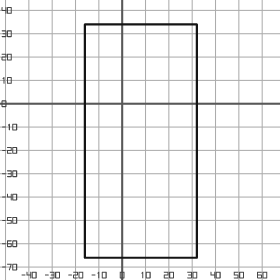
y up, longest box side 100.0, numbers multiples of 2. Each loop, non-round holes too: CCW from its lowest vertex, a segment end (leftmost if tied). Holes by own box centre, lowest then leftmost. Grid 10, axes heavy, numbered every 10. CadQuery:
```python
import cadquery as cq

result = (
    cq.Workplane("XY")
    .moveTo(-16.0, -66.0)
    .lineTo(32.0, -66.0)
    .lineTo(32.0, 34.0)
    .lineTo(-16.0, 34.0)
    .close()
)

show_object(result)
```